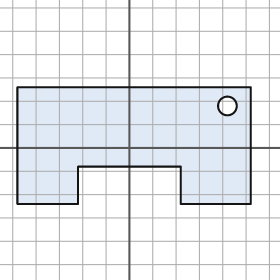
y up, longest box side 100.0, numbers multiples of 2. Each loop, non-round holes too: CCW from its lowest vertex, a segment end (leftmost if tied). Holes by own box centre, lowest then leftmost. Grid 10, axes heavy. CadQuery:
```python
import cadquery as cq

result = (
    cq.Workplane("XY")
    .moveTo(-48.0, -24.0)
    .lineTo(-22.0, -24.0)
    .lineTo(-22.0, -8.0)
    .lineTo(22.0, -8.0)
    .lineTo(22.0, -24.0)
    .lineTo(52.0, -24.0)
    .lineTo(52.0, 26.0)
    .lineTo(-48.0, 26.0)
    .close()
    .moveTo(42.0, 18.0)
    .circle(4.0)
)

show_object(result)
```